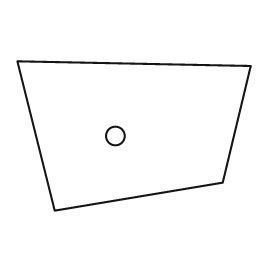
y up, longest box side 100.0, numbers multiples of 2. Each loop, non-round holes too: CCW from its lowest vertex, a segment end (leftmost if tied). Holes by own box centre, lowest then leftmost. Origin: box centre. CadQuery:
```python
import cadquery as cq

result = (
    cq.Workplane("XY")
    .moveTo(-34.0, -32.0)
    .lineTo(38.0, -20.0)
    .lineTo(50.0, 30.0)
    .lineTo(-50.0, 32.0)
    .close()
    .moveTo(-8.0, 0.0)
    .circle(4.0)
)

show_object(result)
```